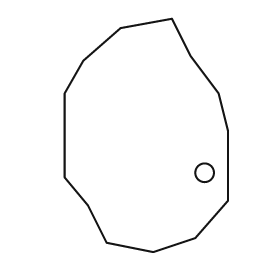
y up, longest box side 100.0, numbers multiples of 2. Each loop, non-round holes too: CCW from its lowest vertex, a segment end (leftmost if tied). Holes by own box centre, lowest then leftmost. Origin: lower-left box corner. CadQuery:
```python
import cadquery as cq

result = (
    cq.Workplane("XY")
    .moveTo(38.0, 0.0)
    .lineTo(56.0, 6.0)
    .lineTo(70.0, 22.0)
    .lineTo(70.0, 52.0)
    .lineTo(66.0, 68.0)
    .lineTo(54.0, 84.0)
    .lineTo(46.0, 100.0)
    .lineTo(24.0, 96.0)
    .lineTo(8.0, 82.0)
    .lineTo(0.0, 68.0)
    .lineTo(0.0, 32.0)
    .lineTo(10.0, 20.0)
    .lineTo(18.0, 4.0)
    .close()
    .moveTo(60.0, 34.0)
    .circle(4.0)
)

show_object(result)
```